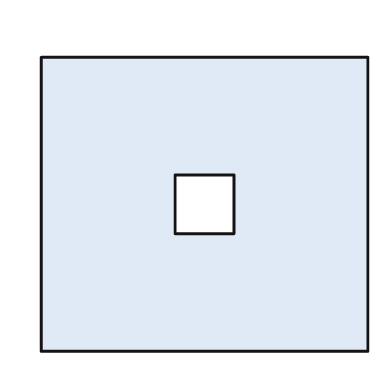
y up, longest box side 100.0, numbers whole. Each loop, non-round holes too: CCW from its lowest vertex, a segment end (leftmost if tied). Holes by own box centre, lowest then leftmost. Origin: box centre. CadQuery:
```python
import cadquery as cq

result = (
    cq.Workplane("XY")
    .moveTo(-50.0, -45.0)
    .lineTo(50.0, -45.0)
    .lineTo(50.0, 45.0)
    .lineTo(-50.0, 45.0)
    .close()
    .moveTo(-9.0, -9.0)
    .lineTo(9.0, -9.0)
    .lineTo(9.0, 9.0)
    .lineTo(-9.0, 9.0)
    .close()
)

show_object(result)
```